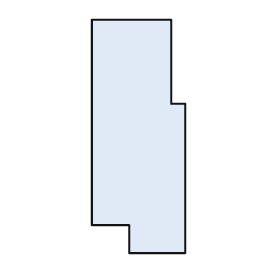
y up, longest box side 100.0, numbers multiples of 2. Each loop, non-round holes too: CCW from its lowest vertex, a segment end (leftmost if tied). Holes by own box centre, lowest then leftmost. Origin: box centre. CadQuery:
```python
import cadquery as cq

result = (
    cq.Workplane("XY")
    .moveTo(-4.0, -50.0)
    .lineTo(20.0, -50.0)
    .lineTo(20.0, 14.0)
    .lineTo(14.0, 14.0)
    .lineTo(14.0, 50.0)
    .lineTo(-20.0, 50.0)
    .lineTo(-20.0, -38.0)
    .lineTo(-4.0, -38.0)
    .close()
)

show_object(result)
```